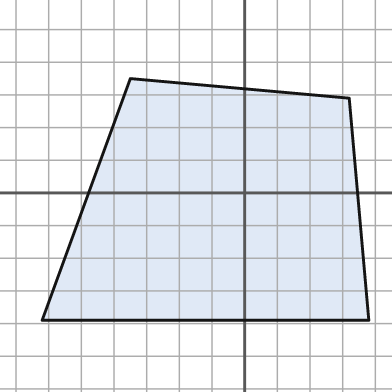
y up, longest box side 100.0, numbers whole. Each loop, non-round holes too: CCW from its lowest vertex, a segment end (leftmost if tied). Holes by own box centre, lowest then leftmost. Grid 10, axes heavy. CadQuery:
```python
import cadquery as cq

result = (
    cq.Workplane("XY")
    .moveTo(-62.0, -39.0)
    .lineTo(38.0, -39.0)
    .lineTo(32.0, 29.0)
    .lineTo(-35.0, 35.0)
    .close()
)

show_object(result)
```